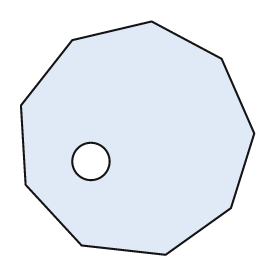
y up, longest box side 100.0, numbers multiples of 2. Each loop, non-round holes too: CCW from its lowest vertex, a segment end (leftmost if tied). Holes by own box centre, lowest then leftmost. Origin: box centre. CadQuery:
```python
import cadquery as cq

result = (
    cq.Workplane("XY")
    .moveTo(12.0, -50.0)
    .lineTo(40.0, -30.0)
    .lineTo(50.0, 2.0)
    .lineTo(36.0, 34.0)
    .lineTo(6.0, 50.0)
    .lineTo(-28.0, 42.0)
    .lineTo(-50.0, 14.0)
    .lineTo(-48.0, -20.0)
    .lineTo(-24.0, -46.0)
    .close()
    .moveTo(-20.0, -10.0)
    .circle(8.0)
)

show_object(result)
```